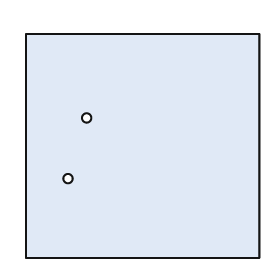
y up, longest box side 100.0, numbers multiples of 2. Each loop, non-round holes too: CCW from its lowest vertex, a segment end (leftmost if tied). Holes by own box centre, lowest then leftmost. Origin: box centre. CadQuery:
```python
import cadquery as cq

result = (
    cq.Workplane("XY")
    .moveTo(-50.0, -48.0)
    .lineTo(50.0, -48.0)
    .lineTo(50.0, 48.0)
    .lineTo(-50.0, 48.0)
    .close()
    .moveTo(-32.0, -14.0)
    .circle(2.0)
    .moveTo(-24.0, 12.0)
    .circle(2.0)
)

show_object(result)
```